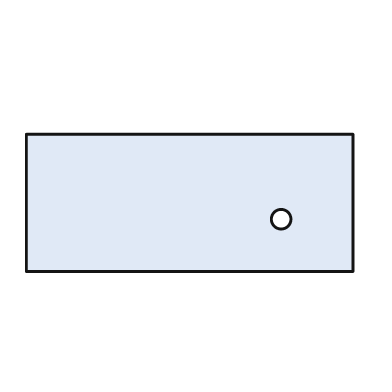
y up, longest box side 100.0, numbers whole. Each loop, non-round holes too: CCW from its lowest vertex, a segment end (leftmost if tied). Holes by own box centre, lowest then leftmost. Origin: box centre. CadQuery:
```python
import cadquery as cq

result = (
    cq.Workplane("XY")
    .moveTo(-50.0, -21.0)
    .lineTo(50.0, -21.0)
    .lineTo(50.0, 21.0)
    .lineTo(-50.0, 21.0)
    .close()
    .moveTo(28.0, -5.0)
    .circle(3.0)
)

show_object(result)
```